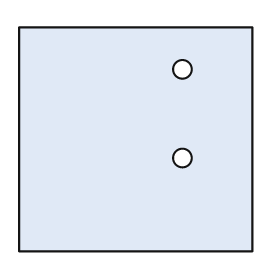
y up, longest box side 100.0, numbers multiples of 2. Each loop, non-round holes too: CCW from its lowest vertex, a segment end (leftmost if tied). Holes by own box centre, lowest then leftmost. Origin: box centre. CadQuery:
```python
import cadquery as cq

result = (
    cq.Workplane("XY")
    .moveTo(-50.0, -48.0)
    .lineTo(50.0, -48.0)
    .lineTo(50.0, 48.0)
    .lineTo(-50.0, 48.0)
    .close()
    .moveTo(20.0, -8.0)
    .circle(4.0)
    .moveTo(20.0, 30.0)
    .circle(4.0)
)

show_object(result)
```